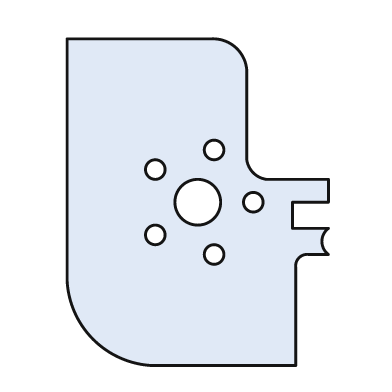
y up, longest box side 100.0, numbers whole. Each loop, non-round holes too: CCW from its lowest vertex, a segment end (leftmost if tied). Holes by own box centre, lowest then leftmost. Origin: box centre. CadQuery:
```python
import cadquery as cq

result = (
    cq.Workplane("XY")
    .moveTo(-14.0, -50.0)
    .lineTo(30.0, -50.0)
    .lineTo(30.0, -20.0)
    .threePointArc((31.0, -17.0), (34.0, -16.0))
    .lineTo(40.0, -16.0)
    .threePointArc((38.0, -12.0), (40.0, -8.0))
    .lineTo(29.0, -8.0)
    .lineTo(29.0, 0.0)
    .lineTo(40.0, 0.0)
    .lineTo(40.0, 7.0)
    .lineTo(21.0, 7.0)
    .threePointArc((17.0, 9.0), (15.0, 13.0))
    .lineTo(15.0, 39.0)
    .threePointArc((12.0, 47.0), (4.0, 50.0))
    .lineTo(-40.0, 50.0)
    .lineTo(-40.0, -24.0)
    .threePointArc((-32.0, -42.0), (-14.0, -50.0))
    .close()
    .moveTo(5.0, -16.0)
    .circle(3.0)
    .moveTo(-13.0, -10.0)
    .circle(3.0)
    .moveTo(0.0, 0.0)
    .circle(7.0)
    .moveTo(17.0, 0.0)
    .circle(3.0)
    .moveTo(-13.0, 10.0)
    .circle(3.0)
    .moveTo(5.0, 16.0)
    .circle(3.0)
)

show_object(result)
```